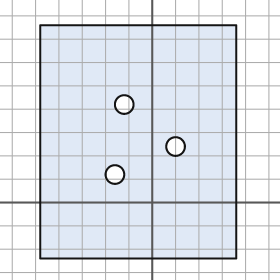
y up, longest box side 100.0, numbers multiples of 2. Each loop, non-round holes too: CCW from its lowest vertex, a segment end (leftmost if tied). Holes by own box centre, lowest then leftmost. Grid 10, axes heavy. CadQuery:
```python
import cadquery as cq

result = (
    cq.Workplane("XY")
    .moveTo(-48.0, -24.0)
    .lineTo(36.0, -24.0)
    .lineTo(36.0, 76.0)
    .lineTo(-48.0, 76.0)
    .close()
    .moveTo(-16.0, 12.0)
    .circle(4.0)
    .moveTo(10.0, 24.0)
    .circle(4.0)
    .moveTo(-12.0, 42.0)
    .circle(4.0)
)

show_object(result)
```